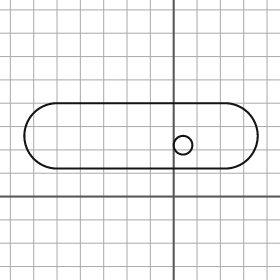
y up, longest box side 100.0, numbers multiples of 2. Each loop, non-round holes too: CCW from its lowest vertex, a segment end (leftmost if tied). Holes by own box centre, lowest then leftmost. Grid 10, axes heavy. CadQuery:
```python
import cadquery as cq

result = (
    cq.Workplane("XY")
    .moveTo(-50.0, 12.0)
    .lineTo(22.0, 12.0)
    .threePointArc((36.0, 26.0), (22.0, 40.0))
    .lineTo(-50.0, 40.0)
    .threePointArc((-64.0, 26.0), (-50.0, 12.0))
    .close()
    .moveTo(4.0, 22.0)
    .circle(4.0)
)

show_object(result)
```